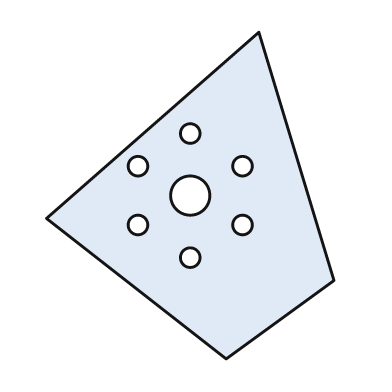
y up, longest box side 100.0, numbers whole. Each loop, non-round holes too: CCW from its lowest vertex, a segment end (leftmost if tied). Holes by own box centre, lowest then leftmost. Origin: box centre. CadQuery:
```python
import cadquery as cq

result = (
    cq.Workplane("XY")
    .moveTo(11.0, -50.0)
    .lineTo(44.0, -26.0)
    .lineTo(21.0, 50.0)
    .lineTo(-44.0, -7.0)
    .close()
    .moveTo(0.0, -19.0)
    .circle(3.0)
    .moveTo(-16.0, -9.0)
    .circle(3.0)
    .moveTo(16.0, -9.0)
    .circle(3.0)
    .moveTo(0.0, 0.0)
    .circle(6.0)
    .moveTo(-16.0, 9.0)
    .circle(3.0)
    .moveTo(16.0, 9.0)
    .circle(3.0)
    .moveTo(0.0, 19.0)
    .circle(3.0)
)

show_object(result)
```